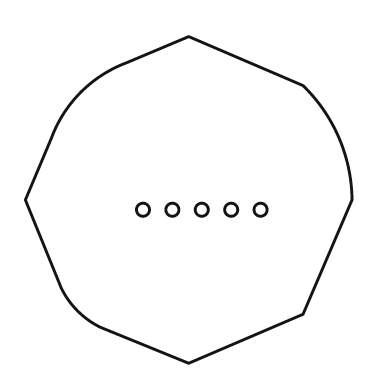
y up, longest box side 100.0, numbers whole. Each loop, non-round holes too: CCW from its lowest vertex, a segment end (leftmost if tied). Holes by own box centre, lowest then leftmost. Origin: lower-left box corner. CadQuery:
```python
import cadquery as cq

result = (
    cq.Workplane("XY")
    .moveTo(50.0, 0.0)
    .lineTo(85.0, 15.0)
    .lineTo(100.0, 50.0)
    .threePointArc((96.0, 69.0), (85.0, 85.0))
    .lineTo(50.0, 100.0)
    .lineTo(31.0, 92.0)
    .threePointArc((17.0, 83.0), (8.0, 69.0))
    .lineTo(0.0, 50.0)
    .lineTo(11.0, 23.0)
    .threePointArc((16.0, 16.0), (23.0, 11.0))
    .close()
    .moveTo(36.0, 47.0)
    .circle(2.0)
    .moveTo(45.0, 47.0)
    .circle(2.0)
    .moveTo(54.0, 47.0)
    .circle(2.0)
    .moveTo(63.0, 47.0)
    .circle(2.0)
    .moveTo(72.0, 47.0)
    .circle(2.0)
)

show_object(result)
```